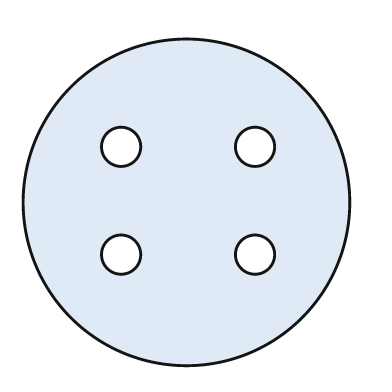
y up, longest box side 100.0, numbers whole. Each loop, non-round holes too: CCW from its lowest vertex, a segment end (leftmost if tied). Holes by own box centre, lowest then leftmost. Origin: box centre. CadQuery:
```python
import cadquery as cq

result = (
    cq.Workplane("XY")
    .moveTo(0.0, 0.0)
    .circle(50.0)
    .moveTo(-20.0, -16.0)
    .circle(6.0)
    .moveTo(21.0, -16.0)
    .circle(6.0)
    .moveTo(-20.0, 17.0)
    .circle(6.0)
    .moveTo(21.0, 17.0)
    .circle(6.0)
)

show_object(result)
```